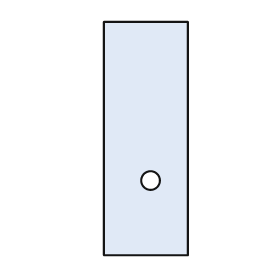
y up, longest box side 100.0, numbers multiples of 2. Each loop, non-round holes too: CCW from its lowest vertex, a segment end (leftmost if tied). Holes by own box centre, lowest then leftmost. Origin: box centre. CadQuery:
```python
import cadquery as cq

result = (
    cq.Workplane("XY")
    .moveTo(-18.0, -50.0)
    .lineTo(18.0, -50.0)
    .lineTo(18.0, 50.0)
    .lineTo(-18.0, 50.0)
    .close()
    .moveTo(2.0, -18.0)
    .circle(4.0)
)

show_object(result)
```